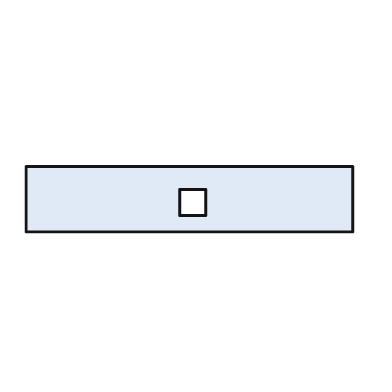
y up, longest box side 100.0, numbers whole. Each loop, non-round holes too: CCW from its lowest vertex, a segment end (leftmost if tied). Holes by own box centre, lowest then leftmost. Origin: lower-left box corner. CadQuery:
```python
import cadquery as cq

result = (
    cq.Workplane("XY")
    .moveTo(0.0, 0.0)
    .lineTo(100.0, 0.0)
    .lineTo(100.0, 20.0)
    .lineTo(0.0, 20.0)
    .close()
    .moveTo(47.0, 5.0)
    .lineTo(55.0, 5.0)
    .lineTo(55.0, 13.0)
    .lineTo(47.0, 13.0)
    .close()
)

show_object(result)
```